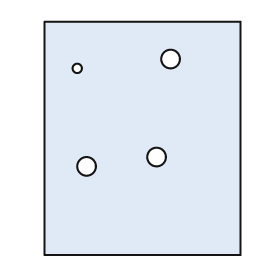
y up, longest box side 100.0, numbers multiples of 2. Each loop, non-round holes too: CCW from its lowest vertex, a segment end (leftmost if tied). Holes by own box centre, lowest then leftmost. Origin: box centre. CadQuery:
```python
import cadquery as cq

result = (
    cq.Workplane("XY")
    .moveTo(-42.0, -50.0)
    .lineTo(42.0, -50.0)
    .lineTo(42.0, 50.0)
    .lineTo(-42.0, 50.0)
    .close()
    .moveTo(-24.0, -12.0)
    .circle(4.0)
    .moveTo(6.0, -8.0)
    .circle(4.0)
    .moveTo(-28.0, 30.0)
    .circle(2.0)
    .moveTo(12.0, 34.0)
    .circle(4.0)
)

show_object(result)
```